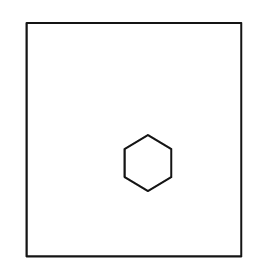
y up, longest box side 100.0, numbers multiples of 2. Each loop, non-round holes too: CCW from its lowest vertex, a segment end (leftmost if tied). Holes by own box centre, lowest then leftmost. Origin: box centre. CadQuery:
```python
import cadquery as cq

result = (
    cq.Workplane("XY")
    .moveTo(-46.0, -50.0)
    .lineTo(46.0, -50.0)
    .lineTo(46.0, 50.0)
    .lineTo(-46.0, 50.0)
    .close()
    .moveTo(6.0, -22.0)
    .lineTo(16.0, -16.0)
    .lineTo(16.0, -4.0)
    .lineTo(6.0, 2.0)
    .lineTo(-4.0, -4.0)
    .lineTo(-4.0, -16.0)
    .close()
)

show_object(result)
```